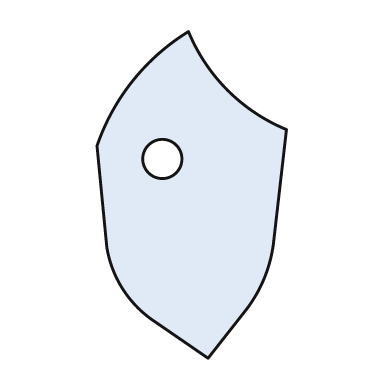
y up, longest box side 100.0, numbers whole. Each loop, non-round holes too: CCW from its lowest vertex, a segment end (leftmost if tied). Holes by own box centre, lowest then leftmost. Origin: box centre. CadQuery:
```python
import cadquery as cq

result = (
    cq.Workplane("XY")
    .moveTo(5.0, -50.0)
    .lineTo(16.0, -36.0)
    .threePointArc((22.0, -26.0), (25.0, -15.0))
    .lineTo(29.0, 20.0)
    .threePointArc((11.0, 32.0), (-1.0, 50.0))
    .threePointArc((-18.0, 35.0), (-29.0, 15.0))
    .lineTo(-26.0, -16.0)
    .threePointArc((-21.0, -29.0), (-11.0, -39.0))
    .close()
    .moveTo(-9.0, 11.0)
    .circle(6.0)
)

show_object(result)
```